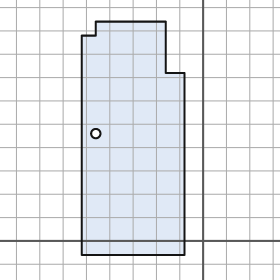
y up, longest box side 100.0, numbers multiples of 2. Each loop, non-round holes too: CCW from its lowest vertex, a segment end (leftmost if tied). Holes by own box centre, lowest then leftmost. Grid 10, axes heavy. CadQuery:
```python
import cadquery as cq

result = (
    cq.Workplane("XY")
    .moveTo(-52.0, -6.0)
    .lineTo(-8.0, -6.0)
    .lineTo(-8.0, 72.0)
    .lineTo(-16.0, 72.0)
    .lineTo(-16.0, 94.0)
    .lineTo(-46.0, 94.0)
    .lineTo(-46.0, 88.0)
    .lineTo(-52.0, 88.0)
    .close()
    .moveTo(-46.0, 46.0)
    .circle(2.0)
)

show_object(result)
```